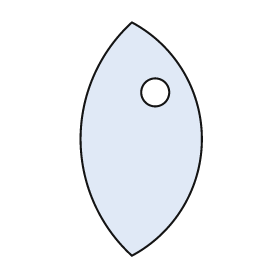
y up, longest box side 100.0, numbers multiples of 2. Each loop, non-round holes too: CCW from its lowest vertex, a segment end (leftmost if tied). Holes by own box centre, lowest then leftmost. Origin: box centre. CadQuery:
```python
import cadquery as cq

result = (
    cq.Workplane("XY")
    .moveTo(-4.0, -50.0)
    .threePointArc((26.0, 0.0), (-4.0, 50.0))
    .threePointArc((-26.0, 0.0), (-4.0, -50.0))
    .close()
    .moveTo(6.0, 20.0)
    .circle(6.0)
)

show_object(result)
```